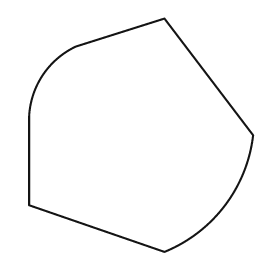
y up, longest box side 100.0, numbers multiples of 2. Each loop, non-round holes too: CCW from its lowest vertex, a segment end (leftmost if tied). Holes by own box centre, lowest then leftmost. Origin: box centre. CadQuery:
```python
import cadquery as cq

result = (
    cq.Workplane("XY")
    .moveTo(10.0, -50.0)
    .threePointArc((36.0, -30.0), (48.0, 0.0))
    .lineTo(10.0, 50.0)
    .lineTo(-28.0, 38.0)
    .threePointArc((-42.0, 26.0), (-48.0, 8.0))
    .lineTo(-48.0, -30.0)
    .close()
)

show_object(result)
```